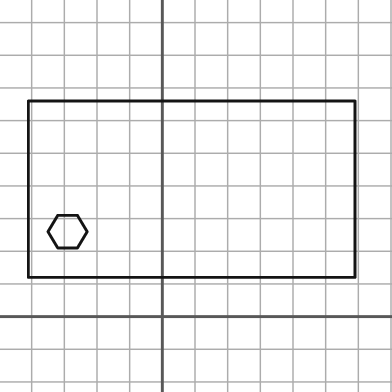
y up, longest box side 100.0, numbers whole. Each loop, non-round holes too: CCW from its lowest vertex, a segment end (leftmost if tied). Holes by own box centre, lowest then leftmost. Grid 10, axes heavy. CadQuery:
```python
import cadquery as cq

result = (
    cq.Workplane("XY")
    .moveTo(-41.0, 12.0)
    .lineTo(59.0, 12.0)
    .lineTo(59.0, 66.0)
    .lineTo(-41.0, 66.0)
    .close()
    .moveTo(-32.0, 21.0)
    .lineTo(-26.0, 21.0)
    .lineTo(-23.0, 26.0)
    .lineTo(-26.0, 31.0)
    .lineTo(-32.0, 31.0)
    .lineTo(-35.0, 26.0)
    .close()
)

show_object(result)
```